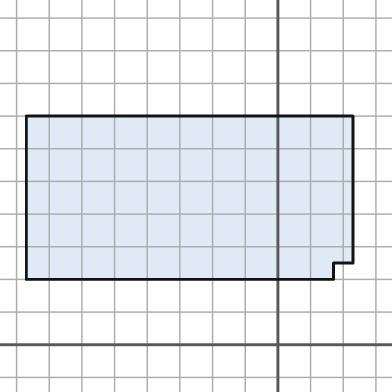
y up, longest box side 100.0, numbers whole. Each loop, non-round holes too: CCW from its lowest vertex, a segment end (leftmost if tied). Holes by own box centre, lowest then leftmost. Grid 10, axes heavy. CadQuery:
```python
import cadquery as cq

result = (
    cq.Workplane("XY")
    .moveTo(-77.0, 20.0)
    .lineTo(17.0, 20.0)
    .lineTo(17.0, 25.0)
    .lineTo(23.0, 25.0)
    .lineTo(23.0, 70.0)
    .lineTo(-77.0, 70.0)
    .close()
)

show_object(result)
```